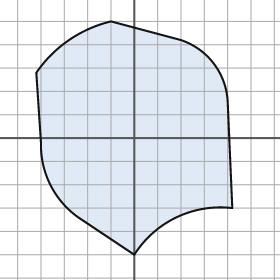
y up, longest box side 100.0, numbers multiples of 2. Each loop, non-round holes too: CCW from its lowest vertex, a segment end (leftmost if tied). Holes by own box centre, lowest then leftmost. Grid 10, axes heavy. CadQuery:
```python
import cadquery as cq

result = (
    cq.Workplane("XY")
    .moveTo(0.0, -50.0)
    .threePointArc((18.0, -34.0), (42.0, -30.0))
    .lineTo(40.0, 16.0)
    .threePointArc((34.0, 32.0), (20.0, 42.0))
    .lineTo(-10.0, 50.0)
    .threePointArc((-28.0, 42.0), (-42.0, 28.0))
    .lineTo(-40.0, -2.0)
    .threePointArc((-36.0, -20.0), (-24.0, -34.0))
    .close()
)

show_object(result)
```